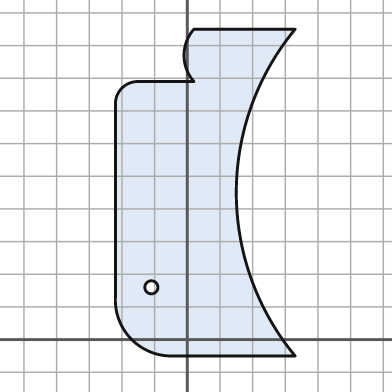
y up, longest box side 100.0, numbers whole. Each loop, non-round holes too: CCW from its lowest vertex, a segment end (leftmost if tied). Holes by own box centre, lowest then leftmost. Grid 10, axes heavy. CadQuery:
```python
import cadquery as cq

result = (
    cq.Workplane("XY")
    .moveTo(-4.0, -5.0)
    .lineTo(33.0, -5.0)
    .threePointArc((15.0, 45.0), (33.0, 95.0))
    .lineTo(2.0, 95.0)
    .threePointArc((-1.0, 87.0), (2.0, 79.0))
    .lineTo(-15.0, 79.0)
    .threePointArc((-20.0, 77.0), (-22.0, 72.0))
    .lineTo(-22.0, 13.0)
    .threePointArc((-17.0, 0.0), (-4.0, -5.0))
    .close()
    .moveTo(-11.0, 16.0)
    .circle(2.0)
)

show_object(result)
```